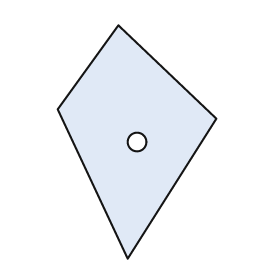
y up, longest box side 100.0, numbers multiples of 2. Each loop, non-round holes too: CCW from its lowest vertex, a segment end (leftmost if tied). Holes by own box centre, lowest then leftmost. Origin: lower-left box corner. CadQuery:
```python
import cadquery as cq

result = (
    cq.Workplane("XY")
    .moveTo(30.0, 0.0)
    .lineTo(68.0, 60.0)
    .lineTo(26.0, 100.0)
    .lineTo(0.0, 64.0)
    .close()
    .moveTo(34.0, 50.0)
    .circle(4.0)
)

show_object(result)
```